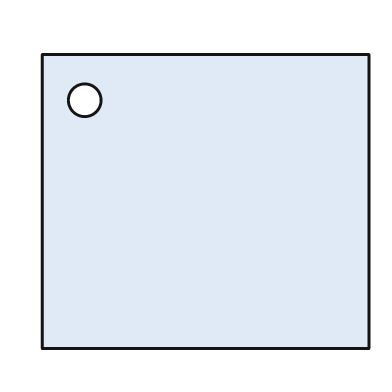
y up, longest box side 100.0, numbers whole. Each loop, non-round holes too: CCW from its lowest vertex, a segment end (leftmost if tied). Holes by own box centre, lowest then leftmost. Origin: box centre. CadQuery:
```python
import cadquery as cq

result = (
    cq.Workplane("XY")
    .moveTo(-50.0, -45.0)
    .lineTo(50.0, -45.0)
    .lineTo(50.0, 45.0)
    .lineTo(-50.0, 45.0)
    .close()
    .moveTo(-37.0, 31.0)
    .circle(5.0)
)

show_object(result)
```